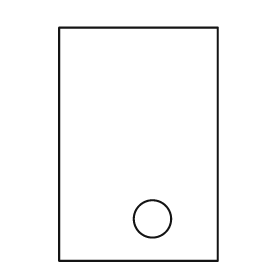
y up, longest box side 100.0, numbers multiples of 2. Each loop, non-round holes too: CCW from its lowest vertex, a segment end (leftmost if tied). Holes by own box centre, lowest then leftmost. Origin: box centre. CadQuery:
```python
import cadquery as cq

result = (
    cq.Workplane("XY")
    .moveTo(-34.0, -50.0)
    .lineTo(34.0, -50.0)
    .lineTo(34.0, 50.0)
    .lineTo(-34.0, 50.0)
    .close()
    .moveTo(6.0, -32.0)
    .circle(8.0)
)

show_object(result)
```